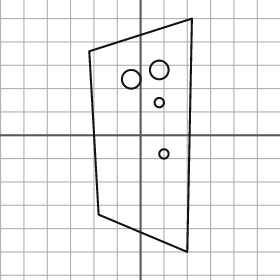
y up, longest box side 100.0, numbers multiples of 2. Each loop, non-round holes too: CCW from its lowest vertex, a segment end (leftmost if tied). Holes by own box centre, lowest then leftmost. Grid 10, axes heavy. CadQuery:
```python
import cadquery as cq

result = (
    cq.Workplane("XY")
    .moveTo(20.0, -50.0)
    .lineTo(22.0, 50.0)
    .lineTo(-22.0, 36.0)
    .lineTo(-18.0, -34.0)
    .close()
    .moveTo(10.0, -8.0)
    .circle(2.0)
    .moveTo(8.0, 14.0)
    .circle(2.0)
    .moveTo(-4.0, 24.0)
    .circle(4.0)
    .moveTo(8.0, 28.0)
    .circle(4.0)
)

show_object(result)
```